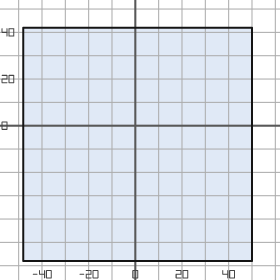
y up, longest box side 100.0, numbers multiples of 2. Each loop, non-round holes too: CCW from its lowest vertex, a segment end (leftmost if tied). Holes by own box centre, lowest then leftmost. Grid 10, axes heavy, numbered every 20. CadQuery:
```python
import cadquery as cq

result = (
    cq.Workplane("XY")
    .moveTo(-48.0, -58.0)
    .lineTo(50.0, -58.0)
    .lineTo(50.0, 42.0)
    .lineTo(-48.0, 42.0)
    .close()
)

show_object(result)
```